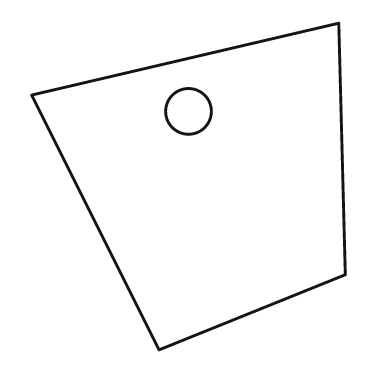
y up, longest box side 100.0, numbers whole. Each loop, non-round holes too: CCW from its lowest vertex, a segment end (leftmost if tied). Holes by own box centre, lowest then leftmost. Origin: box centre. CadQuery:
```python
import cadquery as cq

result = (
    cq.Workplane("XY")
    .moveTo(-9.0, -50.0)
    .lineTo(48.0, -27.0)
    .lineTo(46.0, 50.0)
    .lineTo(-48.0, 28.0)
    .close()
    .moveTo(0.0, 23.0)
    .circle(7.0)
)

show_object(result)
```